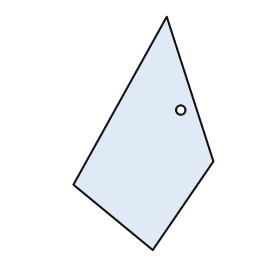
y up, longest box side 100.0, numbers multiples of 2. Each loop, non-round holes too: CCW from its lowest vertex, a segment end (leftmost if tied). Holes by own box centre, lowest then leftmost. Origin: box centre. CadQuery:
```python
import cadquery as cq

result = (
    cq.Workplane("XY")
    .moveTo(4.0, -50.0)
    .lineTo(30.0, -12.0)
    .lineTo(10.0, 50.0)
    .lineTo(-30.0, -22.0)
    .close()
    .moveTo(16.0, 10.0)
    .circle(2.0)
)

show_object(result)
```